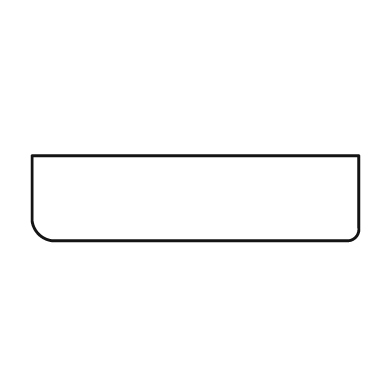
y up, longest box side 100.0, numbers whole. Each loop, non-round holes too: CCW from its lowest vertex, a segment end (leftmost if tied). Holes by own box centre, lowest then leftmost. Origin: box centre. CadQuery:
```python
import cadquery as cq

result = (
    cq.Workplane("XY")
    .moveTo(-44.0, -13.0)
    .lineTo(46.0, -13.0)
    .threePointArc((49.0, -12.0), (50.0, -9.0))
    .lineTo(50.0, 13.0)
    .lineTo(-50.0, 13.0)
    .lineTo(-50.0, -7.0)
    .threePointArc((-48.0, -11.0), (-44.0, -13.0))
    .close()
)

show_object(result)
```